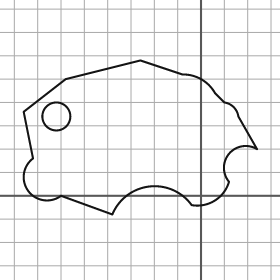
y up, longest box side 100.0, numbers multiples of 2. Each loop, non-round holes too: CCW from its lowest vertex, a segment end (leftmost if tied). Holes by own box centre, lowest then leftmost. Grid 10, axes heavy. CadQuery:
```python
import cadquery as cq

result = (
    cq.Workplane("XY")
    .moveTo(-38.0, -8.0)
    .threePointArc((-22.0, 4.0), (-4.0, -4.0))
    .threePointArc((6.0, -2.0), (12.0, 6.0))
    .threePointArc((12.0, 18.0), (24.0, 20.0))
    .lineTo(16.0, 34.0)
    .threePointArc((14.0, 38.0), (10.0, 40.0))
    .lineTo(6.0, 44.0)
    .threePointArc((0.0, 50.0), (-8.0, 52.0))
    .lineTo(-26.0, 58.0)
    .lineTo(-58.0, 50.0)
    .lineTo(-76.0, 36.0)
    .lineTo(-72.0, 16.0)
    .threePointArc((-74.0, 2.0), (-60.0, 0.0))
    .close()
    .moveTo(-62.0, 34.0)
    .circle(6.0)
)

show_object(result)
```